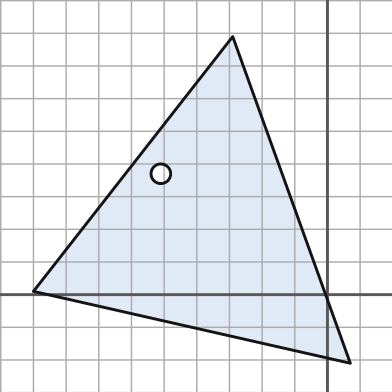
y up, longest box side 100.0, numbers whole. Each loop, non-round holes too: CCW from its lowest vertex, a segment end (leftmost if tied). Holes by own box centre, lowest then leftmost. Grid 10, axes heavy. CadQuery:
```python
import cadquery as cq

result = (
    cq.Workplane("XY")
    .moveTo(7.0, -21.0)
    .lineTo(-29.0, 79.0)
    .lineTo(-90.0, 1.0)
    .close()
    .moveTo(-51.0, 37.0)
    .circle(3.0)
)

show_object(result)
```